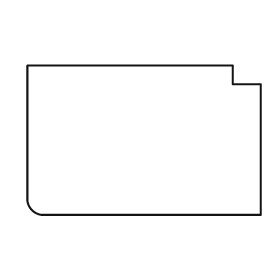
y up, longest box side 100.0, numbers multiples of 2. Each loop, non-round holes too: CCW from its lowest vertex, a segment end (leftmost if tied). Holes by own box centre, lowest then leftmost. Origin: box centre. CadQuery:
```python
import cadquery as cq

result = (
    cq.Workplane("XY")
    .moveTo(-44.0, -32.0)
    .lineTo(50.0, -32.0)
    .lineTo(50.0, 24.0)
    .lineTo(38.0, 24.0)
    .lineTo(38.0, 32.0)
    .lineTo(-50.0, 32.0)
    .lineTo(-50.0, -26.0)
    .threePointArc((-48.0, -30.0), (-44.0, -32.0))
    .close()
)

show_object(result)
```